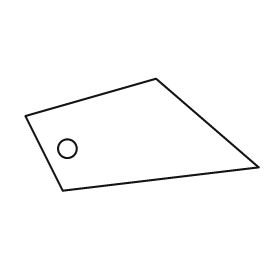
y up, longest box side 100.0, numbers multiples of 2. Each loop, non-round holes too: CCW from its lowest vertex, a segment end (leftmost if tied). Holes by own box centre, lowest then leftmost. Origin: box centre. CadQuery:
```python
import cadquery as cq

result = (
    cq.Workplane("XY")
    .moveTo(-34.0, -24.0)
    .lineTo(50.0, -14.0)
    .lineTo(6.0, 24.0)
    .lineTo(-50.0, 8.0)
    .close()
    .moveTo(-32.0, -6.0)
    .circle(4.0)
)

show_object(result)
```